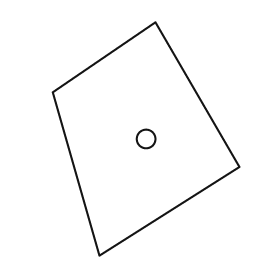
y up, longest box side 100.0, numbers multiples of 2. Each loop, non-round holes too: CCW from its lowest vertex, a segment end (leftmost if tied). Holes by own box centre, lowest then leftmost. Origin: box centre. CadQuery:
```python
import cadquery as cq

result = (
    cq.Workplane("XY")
    .moveTo(-20.0, -50.0)
    .lineTo(40.0, -12.0)
    .lineTo(4.0, 50.0)
    .lineTo(-40.0, 20.0)
    .close()
    .moveTo(0.0, 0.0)
    .circle(4.0)
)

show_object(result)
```